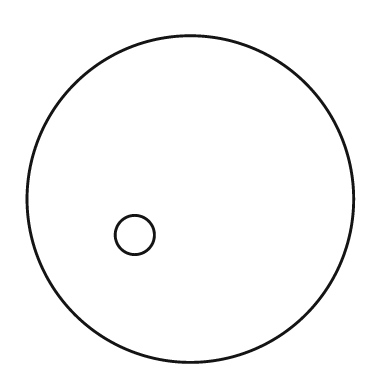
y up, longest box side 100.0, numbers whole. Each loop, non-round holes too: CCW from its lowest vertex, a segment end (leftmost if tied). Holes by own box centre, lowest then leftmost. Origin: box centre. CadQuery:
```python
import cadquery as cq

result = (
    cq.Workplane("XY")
    .moveTo(0.0, 0.0)
    .circle(50.0)
    .moveTo(-17.0, -11.0)
    .circle(6.0)
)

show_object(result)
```